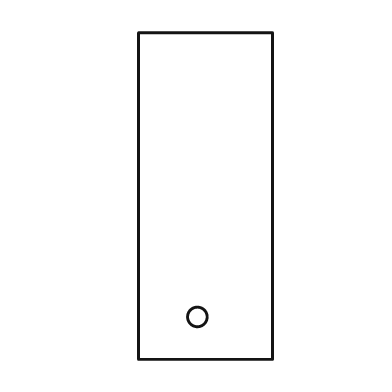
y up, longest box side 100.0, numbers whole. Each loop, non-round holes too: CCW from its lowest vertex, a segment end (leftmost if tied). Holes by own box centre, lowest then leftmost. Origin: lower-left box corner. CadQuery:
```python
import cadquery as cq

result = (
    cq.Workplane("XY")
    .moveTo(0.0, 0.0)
    .lineTo(41.0, 0.0)
    .lineTo(41.0, 100.0)
    .lineTo(0.0, 100.0)
    .close()
    .moveTo(18.0, 13.0)
    .circle(3.0)
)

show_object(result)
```